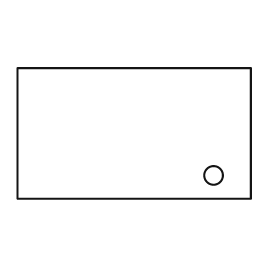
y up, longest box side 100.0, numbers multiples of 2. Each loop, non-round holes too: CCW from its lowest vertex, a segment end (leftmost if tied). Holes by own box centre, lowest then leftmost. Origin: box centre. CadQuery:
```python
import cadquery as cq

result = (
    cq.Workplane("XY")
    .moveTo(-50.0, -28.0)
    .lineTo(50.0, -28.0)
    .lineTo(50.0, 28.0)
    .lineTo(-50.0, 28.0)
    .close()
    .moveTo(34.0, -18.0)
    .circle(4.0)
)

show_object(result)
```